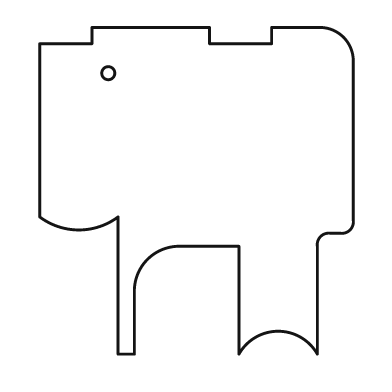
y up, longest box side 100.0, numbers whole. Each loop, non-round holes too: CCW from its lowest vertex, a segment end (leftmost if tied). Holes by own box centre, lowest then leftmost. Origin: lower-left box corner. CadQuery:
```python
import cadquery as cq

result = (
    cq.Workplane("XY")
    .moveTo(24.0, 0.0)
    .lineTo(29.0, 0.0)
    .lineTo(29.0, 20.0)
    .threePointArc((33.0, 29.0), (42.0, 33.0))
    .lineTo(61.0, 33.0)
    .lineTo(61.0, 0.0)
    .threePointArc((73.0, 7.0), (85.0, 0.0))
    .lineTo(85.0, 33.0)
    .threePointArc((86.0, 36.0), (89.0, 37.0))
    .lineTo(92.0, 37.0)
    .threePointArc((95.0, 38.0), (96.0, 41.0))
    .lineTo(96.0, 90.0)
    .threePointArc((93.0, 97.0), (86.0, 100.0))
    .lineTo(71.0, 100.0)
    .lineTo(71.0, 95.0)
    .lineTo(52.0, 95.0)
    .lineTo(52.0, 100.0)
    .lineTo(16.0, 100.0)
    .lineTo(16.0, 95.0)
    .lineTo(0.0, 95.0)
    .lineTo(0.0, 42.0)
    .threePointArc((12.0, 38.0), (24.0, 42.0))
    .close()
    .moveTo(21.0, 86.0)
    .circle(2.0)
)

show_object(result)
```